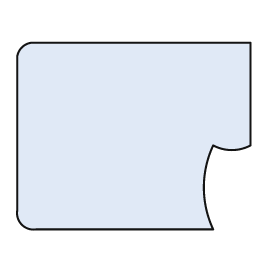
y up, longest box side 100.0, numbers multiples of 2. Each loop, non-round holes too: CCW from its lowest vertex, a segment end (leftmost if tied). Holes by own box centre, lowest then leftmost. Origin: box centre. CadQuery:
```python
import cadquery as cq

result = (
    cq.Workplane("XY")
    .moveTo(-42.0, -40.0)
    .lineTo(34.0, -40.0)
    .threePointArc((30.0, -22.0), (34.0, -4.0))
    .threePointArc((42.0, -6.0), (50.0, -4.0))
    .lineTo(50.0, 40.0)
    .lineTo(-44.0, 40.0)
    .threePointArc((-48.0, 38.0), (-50.0, 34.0))
    .lineTo(-50.0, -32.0)
    .threePointArc((-48.0, -38.0), (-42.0, -40.0))
    .close()
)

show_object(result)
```